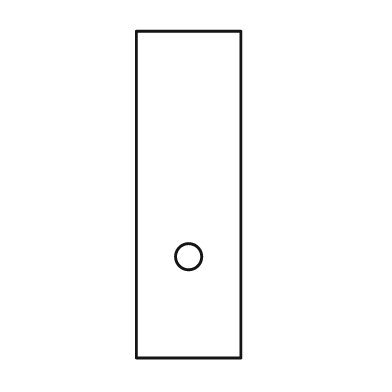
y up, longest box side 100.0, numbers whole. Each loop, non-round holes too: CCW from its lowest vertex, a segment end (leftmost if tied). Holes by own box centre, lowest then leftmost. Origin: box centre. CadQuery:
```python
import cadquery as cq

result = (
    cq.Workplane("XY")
    .moveTo(-16.0, -50.0)
    .lineTo(16.0, -50.0)
    .lineTo(16.0, 50.0)
    .lineTo(-16.0, 50.0)
    .close()
    .moveTo(0.0, -19.0)
    .circle(4.0)
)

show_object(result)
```